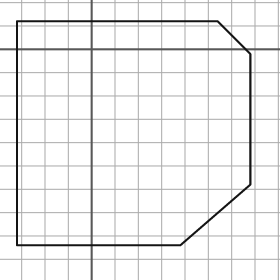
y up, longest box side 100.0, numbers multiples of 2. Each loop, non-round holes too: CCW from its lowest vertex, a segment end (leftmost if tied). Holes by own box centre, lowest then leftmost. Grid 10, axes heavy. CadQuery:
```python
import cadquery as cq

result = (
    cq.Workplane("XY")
    .moveTo(-32.0, -84.0)
    .lineTo(38.0, -84.0)
    .lineTo(68.0, -58.0)
    .lineTo(68.0, -2.0)
    .lineTo(54.0, 12.0)
    .lineTo(-32.0, 12.0)
    .close()
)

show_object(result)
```